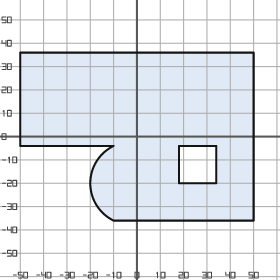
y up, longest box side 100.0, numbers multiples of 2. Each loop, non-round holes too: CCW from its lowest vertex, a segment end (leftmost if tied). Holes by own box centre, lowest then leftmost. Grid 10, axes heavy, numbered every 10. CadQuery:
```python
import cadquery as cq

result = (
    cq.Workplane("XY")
    .moveTo(-10.0, -36.0)
    .lineTo(50.0, -36.0)
    .lineTo(50.0, 36.0)
    .lineTo(-50.0, 36.0)
    .lineTo(-50.0, -4.0)
    .lineTo(-10.0, -4.0)
    .threePointArc((-20.0, -20.0), (-10.0, -36.0))
    .close()
    .moveTo(18.0, -20.0)
    .lineTo(34.0, -20.0)
    .lineTo(34.0, -4.0)
    .lineTo(18.0, -4.0)
    .close()
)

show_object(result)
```